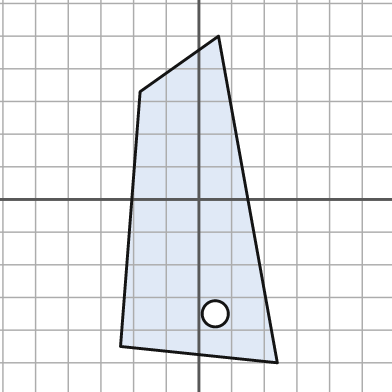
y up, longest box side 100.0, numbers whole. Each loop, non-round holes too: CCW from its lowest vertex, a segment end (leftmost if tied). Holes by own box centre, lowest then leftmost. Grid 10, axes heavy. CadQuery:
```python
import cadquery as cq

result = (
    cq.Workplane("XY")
    .moveTo(24.0, -50.0)
    .lineTo(6.0, 50.0)
    .lineTo(-18.0, 33.0)
    .lineTo(-24.0, -45.0)
    .close()
    .moveTo(5.0, -35.0)
    .circle(4.0)
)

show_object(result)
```